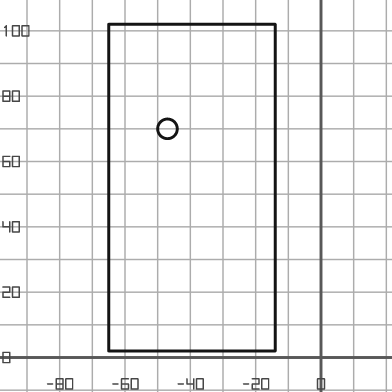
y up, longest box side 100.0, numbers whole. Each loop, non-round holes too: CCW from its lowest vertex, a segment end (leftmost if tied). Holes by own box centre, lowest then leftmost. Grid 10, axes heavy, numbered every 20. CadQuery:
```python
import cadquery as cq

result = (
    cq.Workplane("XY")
    .moveTo(-65.0, 2.0)
    .lineTo(-14.0, 2.0)
    .lineTo(-14.0, 102.0)
    .lineTo(-65.0, 102.0)
    .close()
    .moveTo(-47.0, 70.0)
    .circle(3.0)
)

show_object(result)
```